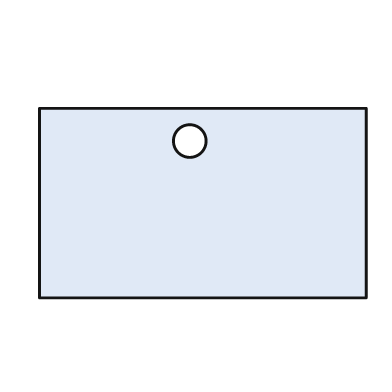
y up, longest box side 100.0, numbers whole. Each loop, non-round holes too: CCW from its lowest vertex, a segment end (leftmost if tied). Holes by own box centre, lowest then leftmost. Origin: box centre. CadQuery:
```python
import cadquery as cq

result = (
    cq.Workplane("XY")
    .moveTo(-50.0, -29.0)
    .lineTo(50.0, -29.0)
    .lineTo(50.0, 29.0)
    .lineTo(-50.0, 29.0)
    .close()
    .moveTo(-4.0, 19.0)
    .circle(5.0)
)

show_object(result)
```